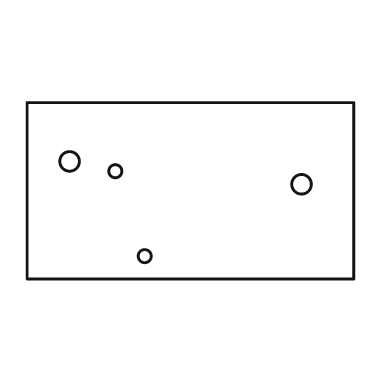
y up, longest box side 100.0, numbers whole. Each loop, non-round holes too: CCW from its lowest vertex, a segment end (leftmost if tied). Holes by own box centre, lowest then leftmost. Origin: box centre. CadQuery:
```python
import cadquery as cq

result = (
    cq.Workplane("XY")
    .moveTo(-50.0, -27.0)
    .lineTo(50.0, -27.0)
    .lineTo(50.0, 27.0)
    .lineTo(-50.0, 27.0)
    .close()
    .moveTo(-14.0, -20.0)
    .circle(2.0)
    .moveTo(34.0, 2.0)
    .circle(3.0)
    .moveTo(-23.0, 6.0)
    .circle(2.0)
    .moveTo(-37.0, 9.0)
    .circle(3.0)
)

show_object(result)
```